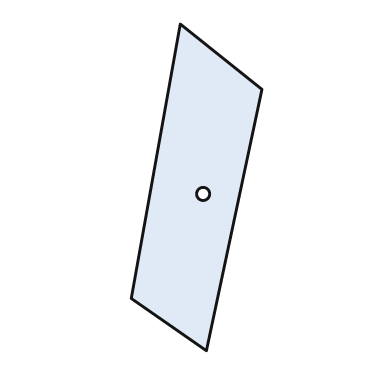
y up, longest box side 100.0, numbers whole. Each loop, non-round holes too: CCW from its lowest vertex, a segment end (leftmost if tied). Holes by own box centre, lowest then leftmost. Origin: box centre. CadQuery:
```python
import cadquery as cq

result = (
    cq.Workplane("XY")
    .moveTo(3.0, -50.0)
    .lineTo(20.0, 30.0)
    .lineTo(-5.0, 50.0)
    .lineTo(-20.0, -34.0)
    .close()
    .moveTo(2.0, -2.0)
    .circle(2.0)
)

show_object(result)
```